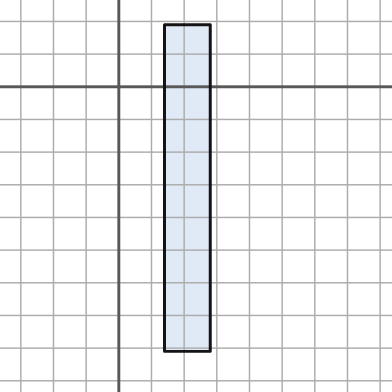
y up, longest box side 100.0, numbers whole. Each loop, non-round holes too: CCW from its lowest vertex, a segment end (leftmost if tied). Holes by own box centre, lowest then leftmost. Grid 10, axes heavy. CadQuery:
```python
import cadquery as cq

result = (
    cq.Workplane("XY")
    .moveTo(14.0, -81.0)
    .lineTo(28.0, -81.0)
    .lineTo(28.0, 19.0)
    .lineTo(14.0, 19.0)
    .close()
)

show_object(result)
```